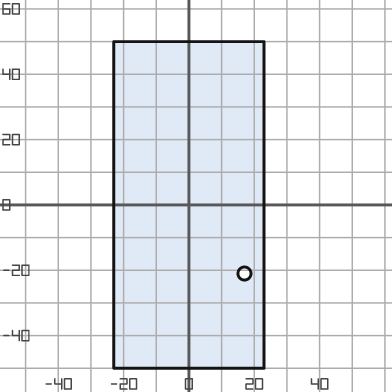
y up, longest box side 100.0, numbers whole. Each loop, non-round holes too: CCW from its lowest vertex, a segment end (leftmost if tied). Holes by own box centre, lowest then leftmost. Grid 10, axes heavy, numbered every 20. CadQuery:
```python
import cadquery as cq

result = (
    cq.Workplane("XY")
    .moveTo(-23.0, -50.0)
    .lineTo(23.0, -50.0)
    .lineTo(23.0, 50.0)
    .lineTo(-23.0, 50.0)
    .close()
    .moveTo(17.0, -21.0)
    .circle(2.0)
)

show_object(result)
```